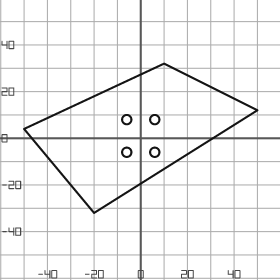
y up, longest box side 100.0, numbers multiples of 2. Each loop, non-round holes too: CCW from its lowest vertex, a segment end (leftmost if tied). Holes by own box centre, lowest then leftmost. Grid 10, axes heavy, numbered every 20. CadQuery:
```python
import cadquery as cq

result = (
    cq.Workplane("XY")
    .moveTo(-20.0, -32.0)
    .lineTo(50.0, 12.0)
    .lineTo(10.0, 32.0)
    .lineTo(-50.0, 4.0)
    .close()
    .moveTo(-6.0, -6.0)
    .circle(2.0)
    .moveTo(6.0, -6.0)
    .circle(2.0)
    .moveTo(-6.0, 8.0)
    .circle(2.0)
    .moveTo(6.0, 8.0)
    .circle(2.0)
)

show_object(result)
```